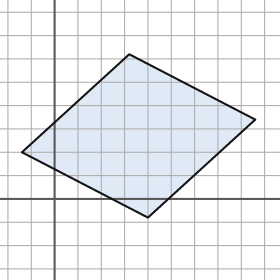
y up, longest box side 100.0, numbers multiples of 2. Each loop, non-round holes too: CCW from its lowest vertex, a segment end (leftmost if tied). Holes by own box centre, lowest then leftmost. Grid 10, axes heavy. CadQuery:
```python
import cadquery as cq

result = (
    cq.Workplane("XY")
    .moveTo(40.0, -8.0)
    .lineTo(86.0, 34.0)
    .lineTo(32.0, 62.0)
    .lineTo(-14.0, 20.0)
    .close()
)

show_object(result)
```